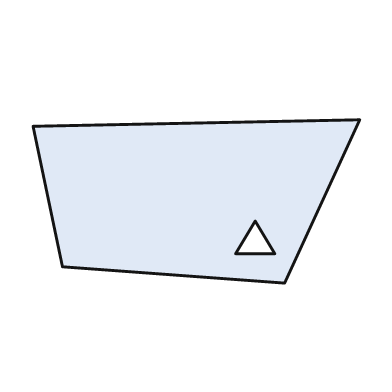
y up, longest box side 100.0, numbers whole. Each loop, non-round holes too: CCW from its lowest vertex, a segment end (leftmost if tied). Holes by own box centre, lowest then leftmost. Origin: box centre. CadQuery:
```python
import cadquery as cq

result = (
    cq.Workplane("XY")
    .moveTo(27.0, -25.0)
    .lineTo(50.0, 25.0)
    .lineTo(-50.0, 23.0)
    .lineTo(-41.0, -20.0)
    .close()
    .moveTo(12.0, -16.0)
    .lineTo(24.0, -16.0)
    .lineTo(18.0, -6.0)
    .close()
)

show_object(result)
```